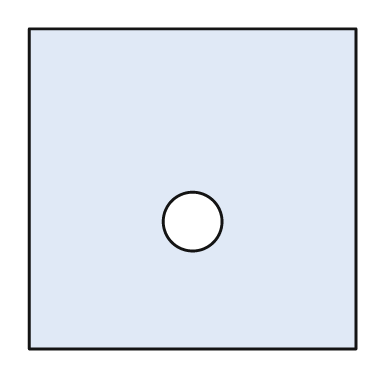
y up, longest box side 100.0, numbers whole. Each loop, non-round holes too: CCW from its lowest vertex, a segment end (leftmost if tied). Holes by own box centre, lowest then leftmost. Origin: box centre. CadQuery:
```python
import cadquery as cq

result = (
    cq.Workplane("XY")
    .moveTo(-50.0, -49.0)
    .lineTo(50.0, -49.0)
    .lineTo(50.0, 49.0)
    .lineTo(-50.0, 49.0)
    .close()
    .moveTo(0.0, -10.0)
    .circle(9.0)
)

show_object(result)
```